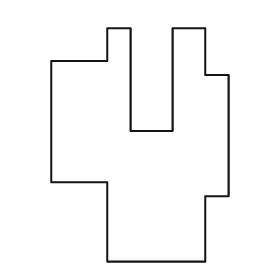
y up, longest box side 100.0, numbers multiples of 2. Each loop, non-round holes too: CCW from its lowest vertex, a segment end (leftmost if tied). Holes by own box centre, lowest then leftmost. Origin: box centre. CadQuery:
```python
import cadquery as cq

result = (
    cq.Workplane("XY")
    .moveTo(-14.0, -50.0)
    .lineTo(28.0, -50.0)
    .lineTo(28.0, -22.0)
    .lineTo(38.0, -22.0)
    .lineTo(38.0, 30.0)
    .lineTo(28.0, 30.0)
    .lineTo(28.0, 50.0)
    .lineTo(14.0, 50.0)
    .lineTo(14.0, 6.0)
    .lineTo(-4.0, 6.0)
    .lineTo(-4.0, 50.0)
    .lineTo(-14.0, 50.0)
    .lineTo(-14.0, 36.0)
    .lineTo(-38.0, 36.0)
    .lineTo(-38.0, -16.0)
    .lineTo(-14.0, -16.0)
    .close()
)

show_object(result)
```